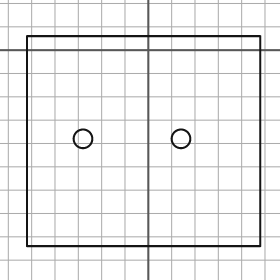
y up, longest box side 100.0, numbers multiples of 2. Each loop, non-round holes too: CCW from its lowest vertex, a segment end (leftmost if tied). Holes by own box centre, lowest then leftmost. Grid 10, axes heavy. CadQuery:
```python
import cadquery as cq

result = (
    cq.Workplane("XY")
    .moveTo(-52.0, -84.0)
    .lineTo(48.0, -84.0)
    .lineTo(48.0, 6.0)
    .lineTo(-52.0, 6.0)
    .close()
    .moveTo(-28.0, -38.0)
    .circle(4.0)
    .moveTo(14.0, -38.0)
    .circle(4.0)
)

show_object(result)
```